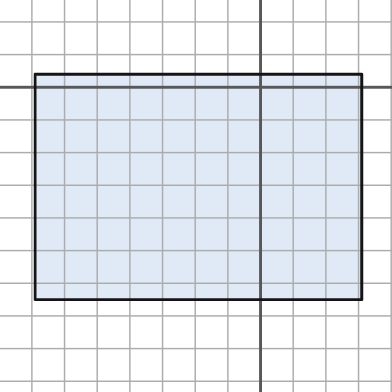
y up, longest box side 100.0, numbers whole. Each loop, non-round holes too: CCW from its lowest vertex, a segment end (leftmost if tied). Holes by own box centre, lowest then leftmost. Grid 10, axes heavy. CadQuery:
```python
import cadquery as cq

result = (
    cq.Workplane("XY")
    .moveTo(-69.0, -65.0)
    .lineTo(31.0, -65.0)
    .lineTo(31.0, 4.0)
    .lineTo(-69.0, 4.0)
    .close()
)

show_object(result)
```